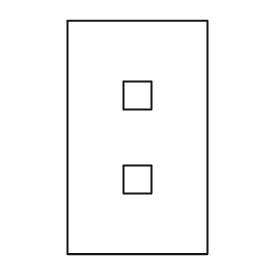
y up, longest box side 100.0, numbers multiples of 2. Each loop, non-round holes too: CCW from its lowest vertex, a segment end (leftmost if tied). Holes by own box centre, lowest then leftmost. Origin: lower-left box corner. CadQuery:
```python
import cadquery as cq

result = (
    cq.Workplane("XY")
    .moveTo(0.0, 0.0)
    .lineTo(60.0, 0.0)
    .lineTo(60.0, 100.0)
    .lineTo(0.0, 100.0)
    .close()
    .moveTo(24.0, 26.0)
    .lineTo(36.0, 26.0)
    .lineTo(36.0, 38.0)
    .lineTo(24.0, 38.0)
    .close()
    .moveTo(24.0, 62.0)
    .lineTo(36.0, 62.0)
    .lineTo(36.0, 74.0)
    .lineTo(24.0, 74.0)
    .close()
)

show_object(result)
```